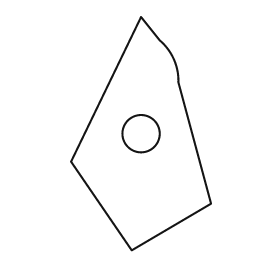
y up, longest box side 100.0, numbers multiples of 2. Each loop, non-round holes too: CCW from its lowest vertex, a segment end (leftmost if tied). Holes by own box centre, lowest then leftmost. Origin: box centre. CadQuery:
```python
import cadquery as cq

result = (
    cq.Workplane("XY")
    .moveTo(-4.0, -50.0)
    .lineTo(30.0, -30.0)
    .lineTo(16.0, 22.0)
    .threePointArc((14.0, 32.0), (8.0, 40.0))
    .lineTo(0.0, 50.0)
    .lineTo(-30.0, -12.0)
    .close()
    .moveTo(0.0, 0.0)
    .circle(8.0)
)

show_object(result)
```